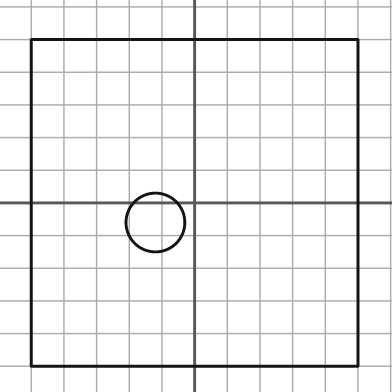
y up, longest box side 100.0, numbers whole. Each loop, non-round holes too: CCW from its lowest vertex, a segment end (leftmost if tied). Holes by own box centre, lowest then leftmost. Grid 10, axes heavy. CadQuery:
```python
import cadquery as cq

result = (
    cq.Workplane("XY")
    .moveTo(-50.0, -50.0)
    .lineTo(50.0, -50.0)
    .lineTo(50.0, 50.0)
    .lineTo(-50.0, 50.0)
    .close()
    .moveTo(-12.0, -6.0)
    .circle(9.0)
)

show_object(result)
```